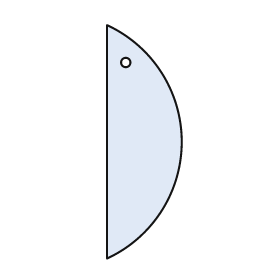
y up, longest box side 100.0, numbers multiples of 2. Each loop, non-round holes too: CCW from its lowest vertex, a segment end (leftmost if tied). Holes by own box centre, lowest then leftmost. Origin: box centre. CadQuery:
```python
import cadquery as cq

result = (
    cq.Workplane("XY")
    .moveTo(-16.0, -50.0)
    .threePointArc((16.0, 0.0), (-16.0, 50.0))
    .close()
    .moveTo(-8.0, 34.0)
    .circle(2.0)
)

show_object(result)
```